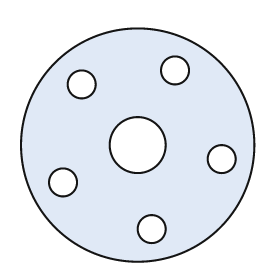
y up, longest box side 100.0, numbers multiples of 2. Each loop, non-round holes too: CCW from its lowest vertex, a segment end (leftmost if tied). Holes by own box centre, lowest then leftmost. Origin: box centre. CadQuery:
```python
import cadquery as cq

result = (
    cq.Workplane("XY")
    .moveTo(0.0, 0.0)
    .circle(50.0)
    .moveTo(6.0, -36.0)
    .circle(6.0)
    .moveTo(-32.0, -16.0)
    .circle(6.0)
    .moveTo(36.0, -6.0)
    .circle(6.0)
    .moveTo(0.0, 0.0)
    .circle(12.0)
    .moveTo(-24.0, 26.0)
    .circle(6.0)
    .moveTo(16.0, 32.0)
    .circle(6.0)
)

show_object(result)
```